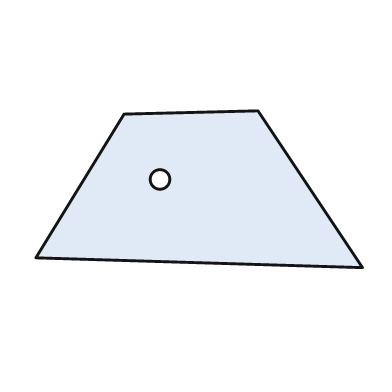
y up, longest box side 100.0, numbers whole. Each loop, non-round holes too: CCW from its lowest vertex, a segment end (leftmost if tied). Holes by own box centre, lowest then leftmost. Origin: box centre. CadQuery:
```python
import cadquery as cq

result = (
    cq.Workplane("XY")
    .moveTo(50.0, -24.0)
    .lineTo(18.0, 24.0)
    .lineTo(-23.0, 23.0)
    .lineTo(-50.0, -21.0)
    .close()
    .moveTo(-12.0, 3.0)
    .circle(3.0)
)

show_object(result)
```